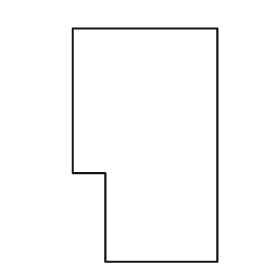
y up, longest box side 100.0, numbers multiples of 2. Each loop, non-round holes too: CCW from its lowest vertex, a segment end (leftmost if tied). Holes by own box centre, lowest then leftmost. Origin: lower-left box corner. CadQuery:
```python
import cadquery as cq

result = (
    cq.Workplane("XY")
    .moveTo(14.0, 0.0)
    .lineTo(62.0, 0.0)
    .lineTo(62.0, 100.0)
    .lineTo(0.0, 100.0)
    .lineTo(0.0, 38.0)
    .lineTo(14.0, 38.0)
    .close()
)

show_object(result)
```